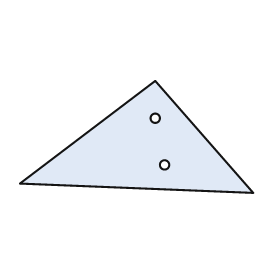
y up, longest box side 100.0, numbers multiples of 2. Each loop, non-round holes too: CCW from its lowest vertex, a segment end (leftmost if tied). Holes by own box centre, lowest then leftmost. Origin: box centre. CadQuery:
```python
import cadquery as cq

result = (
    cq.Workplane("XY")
    .moveTo(50.0, -24.0)
    .lineTo(8.0, 24.0)
    .lineTo(-50.0, -20.0)
    .close()
    .moveTo(12.0, -12.0)
    .circle(2.0)
    .moveTo(8.0, 8.0)
    .circle(2.0)
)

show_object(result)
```